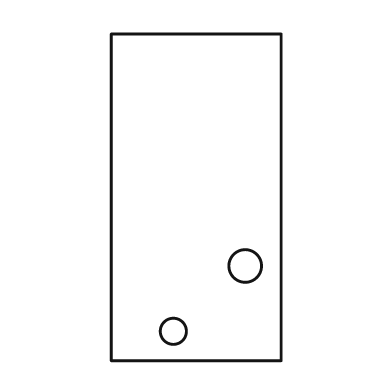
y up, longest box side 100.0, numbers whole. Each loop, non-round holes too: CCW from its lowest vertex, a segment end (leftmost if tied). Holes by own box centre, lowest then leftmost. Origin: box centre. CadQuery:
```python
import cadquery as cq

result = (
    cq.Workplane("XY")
    .moveTo(-26.0, -50.0)
    .lineTo(26.0, -50.0)
    .lineTo(26.0, 50.0)
    .lineTo(-26.0, 50.0)
    .close()
    .moveTo(-7.0, -41.0)
    .circle(4.0)
    .moveTo(15.0, -21.0)
    .circle(5.0)
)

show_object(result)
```